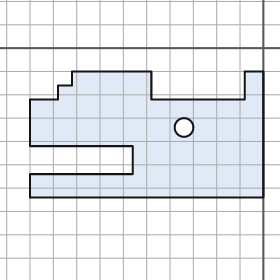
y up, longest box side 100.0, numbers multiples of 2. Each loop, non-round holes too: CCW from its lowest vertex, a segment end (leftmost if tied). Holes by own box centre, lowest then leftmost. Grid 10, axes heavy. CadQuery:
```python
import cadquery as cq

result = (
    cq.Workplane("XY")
    .moveTo(-100.0, -64.0)
    .lineTo(0.0, -64.0)
    .lineTo(0.0, -10.0)
    .lineTo(-8.0, -10.0)
    .lineTo(-8.0, -22.0)
    .lineTo(-48.0, -22.0)
    .lineTo(-48.0, -10.0)
    .lineTo(-82.0, -10.0)
    .lineTo(-82.0, -16.0)
    .lineTo(-88.0, -16.0)
    .lineTo(-88.0, -22.0)
    .lineTo(-100.0, -22.0)
    .lineTo(-100.0, -42.0)
    .lineTo(-56.0, -42.0)
    .lineTo(-56.0, -54.0)
    .lineTo(-100.0, -54.0)
    .close()
    .moveTo(-34.0, -34.0)
    .circle(4.0)
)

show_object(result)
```